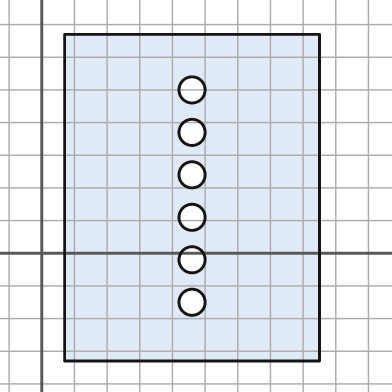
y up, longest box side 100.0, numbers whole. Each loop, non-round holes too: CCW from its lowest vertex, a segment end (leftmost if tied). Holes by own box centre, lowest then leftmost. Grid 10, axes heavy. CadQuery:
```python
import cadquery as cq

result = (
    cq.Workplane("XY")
    .moveTo(7.0, -33.0)
    .lineTo(85.0, -33.0)
    .lineTo(85.0, 67.0)
    .lineTo(7.0, 67.0)
    .close()
    .moveTo(46.0, -15.0)
    .circle(4.0)
    .moveTo(46.0, -2.0)
    .circle(4.0)
    .moveTo(46.0, 11.0)
    .circle(4.0)
    .moveTo(46.0, 24.0)
    .circle(4.0)
    .moveTo(46.0, 37.0)
    .circle(4.0)
    .moveTo(46.0, 50.0)
    .circle(4.0)
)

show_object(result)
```